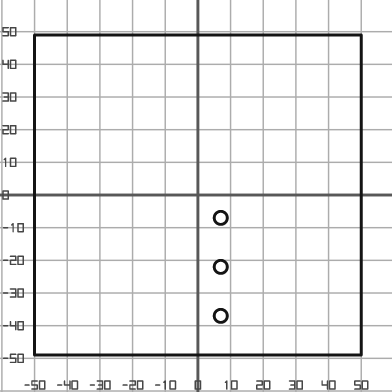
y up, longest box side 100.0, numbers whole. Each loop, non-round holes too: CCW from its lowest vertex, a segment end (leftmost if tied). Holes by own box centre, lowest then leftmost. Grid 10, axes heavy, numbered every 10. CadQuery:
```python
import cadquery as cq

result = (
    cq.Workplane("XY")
    .moveTo(-50.0, -49.0)
    .lineTo(50.0, -49.0)
    .lineTo(50.0, 49.0)
    .lineTo(-50.0, 49.0)
    .close()
    .moveTo(7.0, -37.0)
    .circle(2.0)
    .moveTo(7.0, -22.0)
    .circle(2.0)
    .moveTo(7.0, -7.0)
    .circle(2.0)
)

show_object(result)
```